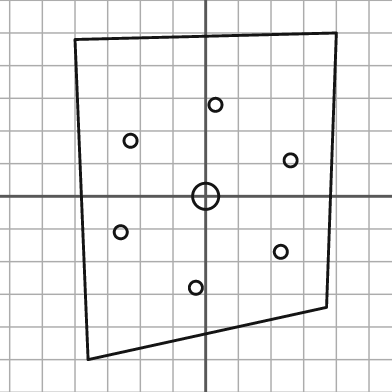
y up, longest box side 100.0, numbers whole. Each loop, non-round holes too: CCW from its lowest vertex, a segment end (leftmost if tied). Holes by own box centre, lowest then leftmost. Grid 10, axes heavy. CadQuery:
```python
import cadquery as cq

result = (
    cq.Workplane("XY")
    .moveTo(-36.0, -50.0)
    .lineTo(37.0, -34.0)
    .lineTo(40.0, 50.0)
    .lineTo(-40.0, 48.0)
    .close()
    .moveTo(-3.0, -28.0)
    .circle(2.0)
    .moveTo(23.0, -17.0)
    .circle(2.0)
    .moveTo(-26.0, -11.0)
    .circle(2.0)
    .moveTo(0.0, 0.0)
    .circle(4.0)
    .moveTo(26.0, 11.0)
    .circle(2.0)
    .moveTo(-23.0, 17.0)
    .circle(2.0)
    .moveTo(3.0, 28.0)
    .circle(2.0)
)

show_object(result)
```